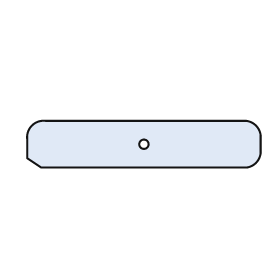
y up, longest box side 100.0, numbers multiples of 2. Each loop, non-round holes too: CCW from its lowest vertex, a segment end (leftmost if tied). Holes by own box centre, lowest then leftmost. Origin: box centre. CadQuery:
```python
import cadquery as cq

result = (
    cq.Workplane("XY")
    .moveTo(-44.0, -10.0)
    .lineTo(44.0, -10.0)
    .threePointArc((48.0, -8.0), (50.0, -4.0))
    .lineTo(50.0, 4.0)
    .threePointArc((48.0, 8.0), (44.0, 10.0))
    .lineTo(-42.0, 10.0)
    .threePointArc((-48.0, 8.0), (-50.0, 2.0))
    .lineTo(-50.0, -6.0)
    .close()
    .moveTo(0.0, 0.0)
    .circle(2.0)
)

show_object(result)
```